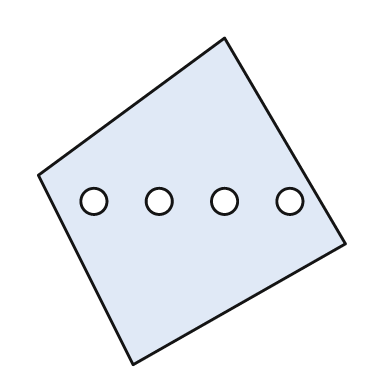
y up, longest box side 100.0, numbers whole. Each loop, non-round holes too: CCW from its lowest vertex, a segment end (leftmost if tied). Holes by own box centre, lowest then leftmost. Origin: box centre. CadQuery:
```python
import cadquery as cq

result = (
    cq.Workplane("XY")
    .moveTo(-18.0, -50.0)
    .lineTo(47.0, -13.0)
    .lineTo(10.0, 50.0)
    .lineTo(-47.0, 8.0)
    .close()
    .moveTo(-30.0, 0.0)
    .circle(4.0)
    .moveTo(-10.0, 0.0)
    .circle(4.0)
    .moveTo(10.0, 0.0)
    .circle(4.0)
    .moveTo(30.0, 0.0)
    .circle(4.0)
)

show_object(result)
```